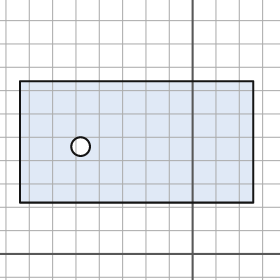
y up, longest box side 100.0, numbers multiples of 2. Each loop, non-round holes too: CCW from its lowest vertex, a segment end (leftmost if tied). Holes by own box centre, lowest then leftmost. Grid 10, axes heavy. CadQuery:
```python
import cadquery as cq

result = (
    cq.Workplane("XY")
    .moveTo(-74.0, 22.0)
    .lineTo(26.0, 22.0)
    .lineTo(26.0, 74.0)
    .lineTo(-74.0, 74.0)
    .close()
    .moveTo(-48.0, 46.0)
    .circle(4.0)
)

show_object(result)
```